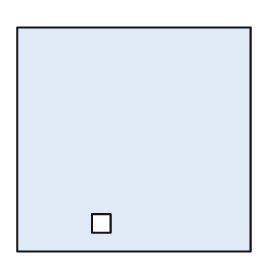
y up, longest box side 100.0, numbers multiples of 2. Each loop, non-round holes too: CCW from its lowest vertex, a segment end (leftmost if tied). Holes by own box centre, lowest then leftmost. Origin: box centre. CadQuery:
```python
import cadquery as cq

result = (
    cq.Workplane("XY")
    .moveTo(-50.0, -48.0)
    .lineTo(50.0, -48.0)
    .lineTo(50.0, 48.0)
    .lineTo(-50.0, 48.0)
    .close()
    .moveTo(-18.0, -40.0)
    .lineTo(-10.0, -40.0)
    .lineTo(-10.0, -32.0)
    .lineTo(-18.0, -32.0)
    .close()
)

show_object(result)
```